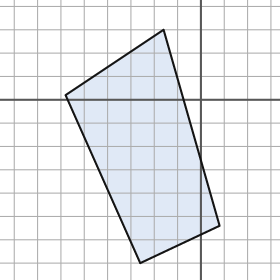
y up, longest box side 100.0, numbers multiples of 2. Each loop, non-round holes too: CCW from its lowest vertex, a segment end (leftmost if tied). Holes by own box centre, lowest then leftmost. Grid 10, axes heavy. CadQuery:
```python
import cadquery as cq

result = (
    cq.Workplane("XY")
    .moveTo(-26.0, -70.0)
    .lineTo(8.0, -54.0)
    .lineTo(-16.0, 30.0)
    .lineTo(-58.0, 2.0)
    .close()
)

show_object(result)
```